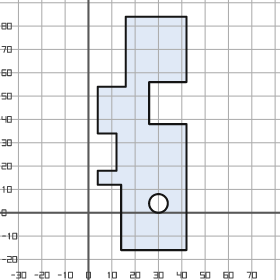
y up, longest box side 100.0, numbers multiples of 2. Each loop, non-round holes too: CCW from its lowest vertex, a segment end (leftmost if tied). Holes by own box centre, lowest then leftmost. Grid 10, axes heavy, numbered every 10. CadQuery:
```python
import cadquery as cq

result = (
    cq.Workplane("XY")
    .moveTo(14.0, -16.0)
    .lineTo(42.0, -16.0)
    .lineTo(42.0, 38.0)
    .lineTo(26.0, 38.0)
    .lineTo(26.0, 56.0)
    .lineTo(42.0, 56.0)
    .lineTo(42.0, 84.0)
    .lineTo(16.0, 84.0)
    .lineTo(16.0, 54.0)
    .lineTo(4.0, 54.0)
    .lineTo(4.0, 34.0)
    .lineTo(12.0, 34.0)
    .lineTo(12.0, 18.0)
    .lineTo(4.0, 18.0)
    .lineTo(4.0, 12.0)
    .lineTo(14.0, 12.0)
    .close()
    .moveTo(30.0, 4.0)
    .circle(4.0)
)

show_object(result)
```